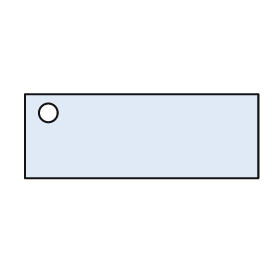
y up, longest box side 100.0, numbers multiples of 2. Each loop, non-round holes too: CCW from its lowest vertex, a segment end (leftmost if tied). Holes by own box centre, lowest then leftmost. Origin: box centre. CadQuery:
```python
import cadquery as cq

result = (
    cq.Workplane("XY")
    .moveTo(-50.0, -18.0)
    .lineTo(50.0, -18.0)
    .lineTo(50.0, 18.0)
    .lineTo(-50.0, 18.0)
    .close()
    .moveTo(-40.0, 10.0)
    .circle(4.0)
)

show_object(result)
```